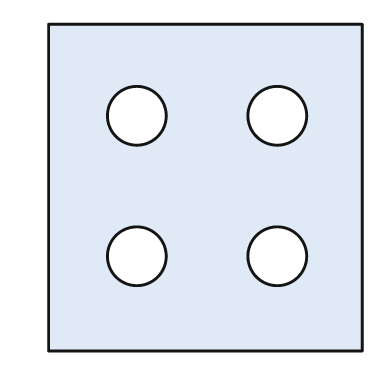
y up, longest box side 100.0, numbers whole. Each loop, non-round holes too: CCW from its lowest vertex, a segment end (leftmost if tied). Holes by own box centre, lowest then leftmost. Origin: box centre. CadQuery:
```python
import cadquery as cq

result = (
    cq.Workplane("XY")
    .moveTo(-48.0, -50.0)
    .lineTo(48.0, -50.0)
    .lineTo(48.0, 50.0)
    .lineTo(-48.0, 50.0)
    .close()
    .moveTo(-21.0, -21.0)
    .circle(9.0)
    .moveTo(22.0, -21.0)
    .circle(9.0)
    .moveTo(-21.0, 22.0)
    .circle(9.0)
    .moveTo(22.0, 22.0)
    .circle(9.0)
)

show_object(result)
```